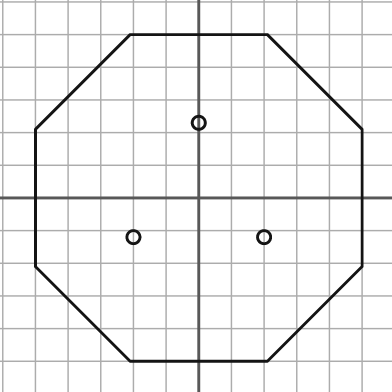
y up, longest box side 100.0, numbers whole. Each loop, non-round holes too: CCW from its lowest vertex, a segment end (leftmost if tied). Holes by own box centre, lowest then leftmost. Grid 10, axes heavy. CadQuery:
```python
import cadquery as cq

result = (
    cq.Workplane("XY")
    .moveTo(-21.0, -50.0)
    .lineTo(21.0, -50.0)
    .lineTo(50.0, -21.0)
    .lineTo(50.0, 21.0)
    .lineTo(21.0, 50.0)
    .lineTo(-21.0, 50.0)
    .lineTo(-50.0, 21.0)
    .lineTo(-50.0, -21.0)
    .close()
    .moveTo(-20.0, -12.0)
    .circle(2.0)
    .moveTo(20.0, -12.0)
    .circle(2.0)
    .moveTo(0.0, 23.0)
    .circle(2.0)
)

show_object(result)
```